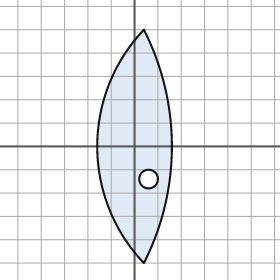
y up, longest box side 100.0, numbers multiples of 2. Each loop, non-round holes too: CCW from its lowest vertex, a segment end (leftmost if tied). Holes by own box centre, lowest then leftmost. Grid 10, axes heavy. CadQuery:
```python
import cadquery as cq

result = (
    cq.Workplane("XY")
    .moveTo(4.0, -50.0)
    .threePointArc((16.0, 0.0), (4.0, 50.0))
    .threePointArc((-16.0, 0.0), (4.0, -50.0))
    .close()
    .moveTo(6.0, -14.0)
    .circle(4.0)
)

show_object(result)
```